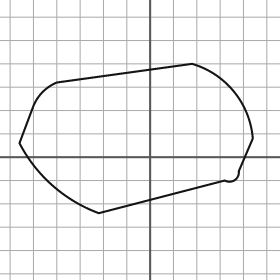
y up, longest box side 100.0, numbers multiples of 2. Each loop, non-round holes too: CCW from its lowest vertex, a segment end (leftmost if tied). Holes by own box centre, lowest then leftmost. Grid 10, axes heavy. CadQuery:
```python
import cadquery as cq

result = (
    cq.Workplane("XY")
    .moveTo(-22.0, -24.0)
    .lineTo(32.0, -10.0)
    .threePointArc((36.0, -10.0), (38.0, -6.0))
    .lineTo(44.0, 8.0)
    .threePointArc((36.0, 28.0), (18.0, 40.0))
    .lineTo(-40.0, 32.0)
    .threePointArc((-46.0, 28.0), (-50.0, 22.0))
    .lineTo(-56.0, 6.0)
    .threePointArc((-42.0, -12.0), (-22.0, -24.0))
    .close()
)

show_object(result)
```